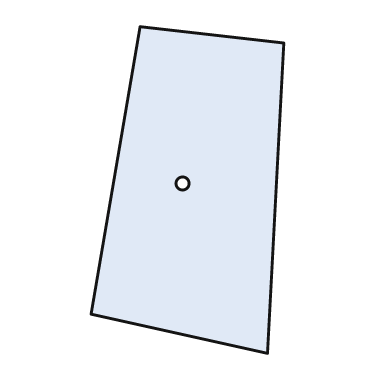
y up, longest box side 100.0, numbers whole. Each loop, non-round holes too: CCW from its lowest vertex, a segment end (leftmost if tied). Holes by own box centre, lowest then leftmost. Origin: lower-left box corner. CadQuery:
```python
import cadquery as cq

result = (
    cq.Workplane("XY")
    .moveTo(54.0, 0.0)
    .lineTo(59.0, 95.0)
    .lineTo(15.0, 100.0)
    .lineTo(0.0, 12.0)
    .close()
    .moveTo(28.0, 52.0)
    .circle(2.0)
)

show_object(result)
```